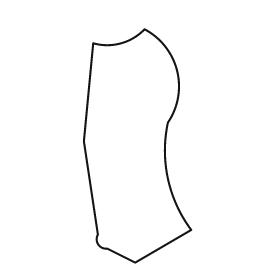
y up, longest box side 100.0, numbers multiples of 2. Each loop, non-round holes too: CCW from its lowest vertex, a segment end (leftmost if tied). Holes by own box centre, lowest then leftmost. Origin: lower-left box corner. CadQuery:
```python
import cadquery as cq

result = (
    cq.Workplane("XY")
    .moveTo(22.0, 0.0)
    .lineTo(46.0, 14.0)
    .threePointArc((36.0, 36.0), (36.0, 60.0))
    .threePointArc((40.0, 82.0), (26.0, 100.0))
    .threePointArc((16.0, 94.0), (4.0, 94.0))
    .lineTo(0.0, 52.0)
    .lineTo(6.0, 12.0)
    .threePointArc((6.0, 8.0), (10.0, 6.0))
    .close()
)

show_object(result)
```